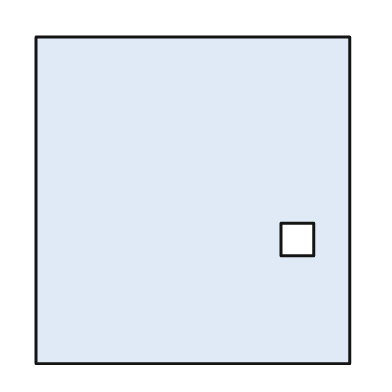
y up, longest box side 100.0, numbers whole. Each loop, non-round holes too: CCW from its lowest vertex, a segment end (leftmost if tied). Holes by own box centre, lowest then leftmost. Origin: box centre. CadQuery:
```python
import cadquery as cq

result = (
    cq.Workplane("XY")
    .moveTo(-48.0, -50.0)
    .lineTo(48.0, -50.0)
    .lineTo(48.0, 50.0)
    .lineTo(-48.0, 50.0)
    .close()
    .moveTo(27.0, -17.0)
    .lineTo(37.0, -17.0)
    .lineTo(37.0, -7.0)
    .lineTo(27.0, -7.0)
    .close()
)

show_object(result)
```